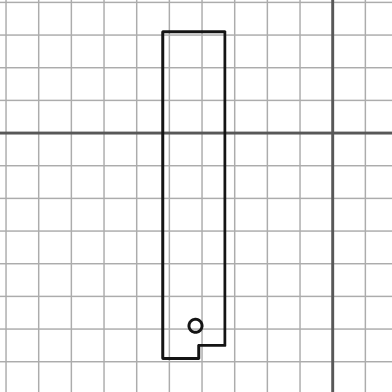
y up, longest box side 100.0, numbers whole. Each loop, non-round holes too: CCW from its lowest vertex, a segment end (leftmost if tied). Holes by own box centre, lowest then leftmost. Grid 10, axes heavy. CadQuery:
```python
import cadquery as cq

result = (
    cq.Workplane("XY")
    .moveTo(-52.0, -69.0)
    .lineTo(-41.0, -69.0)
    .lineTo(-41.0, -65.0)
    .lineTo(-33.0, -65.0)
    .lineTo(-33.0, 31.0)
    .lineTo(-52.0, 31.0)
    .close()
    .moveTo(-42.0, -59.0)
    .circle(2.0)
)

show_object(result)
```